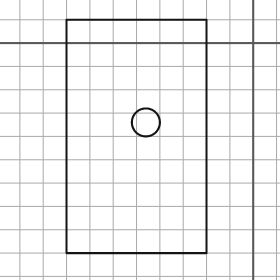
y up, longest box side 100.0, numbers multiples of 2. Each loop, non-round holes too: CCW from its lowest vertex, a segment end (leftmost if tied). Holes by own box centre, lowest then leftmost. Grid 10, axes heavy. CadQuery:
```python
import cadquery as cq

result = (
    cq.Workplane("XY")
    .moveTo(-80.0, -90.0)
    .lineTo(-20.0, -90.0)
    .lineTo(-20.0, 10.0)
    .lineTo(-80.0, 10.0)
    .close()
    .moveTo(-46.0, -34.0)
    .circle(6.0)
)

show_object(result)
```